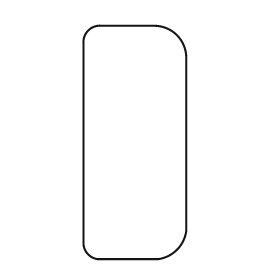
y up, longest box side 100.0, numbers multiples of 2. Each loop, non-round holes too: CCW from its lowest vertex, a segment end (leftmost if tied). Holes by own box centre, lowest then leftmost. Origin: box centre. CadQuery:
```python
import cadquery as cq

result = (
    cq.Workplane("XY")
    .moveTo(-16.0, -50.0)
    .lineTo(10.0, -50.0)
    .threePointArc((18.0, -46.0), (22.0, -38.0))
    .lineTo(22.0, 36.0)
    .threePointArc((18.0, 46.0), (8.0, 50.0))
    .lineTo(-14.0, 50.0)
    .threePointArc((-20.0, 48.0), (-22.0, 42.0))
    .lineTo(-22.0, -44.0)
    .threePointArc((-20.0, -48.0), (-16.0, -50.0))
    .close()
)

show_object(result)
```